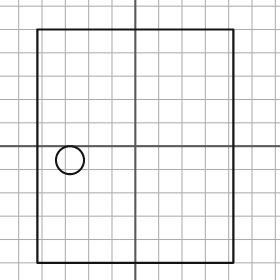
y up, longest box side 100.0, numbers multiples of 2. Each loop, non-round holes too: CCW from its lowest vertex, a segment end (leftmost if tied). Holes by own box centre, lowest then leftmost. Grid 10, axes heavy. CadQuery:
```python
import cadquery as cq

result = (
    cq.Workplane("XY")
    .moveTo(-42.0, -50.0)
    .lineTo(42.0, -50.0)
    .lineTo(42.0, 50.0)
    .lineTo(-42.0, 50.0)
    .close()
    .moveTo(-28.0, -6.0)
    .circle(6.0)
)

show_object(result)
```